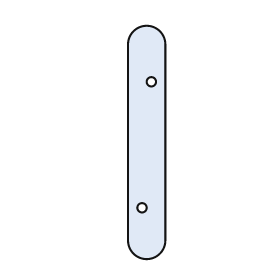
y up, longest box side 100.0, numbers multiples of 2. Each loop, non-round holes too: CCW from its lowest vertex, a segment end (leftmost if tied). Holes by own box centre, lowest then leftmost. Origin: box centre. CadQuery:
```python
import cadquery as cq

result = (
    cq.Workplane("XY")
    .moveTo(-8.0, -42.0)
    .threePointArc((0.0, -50.0), (8.0, -42.0))
    .lineTo(8.0, 42.0)
    .threePointArc((0.0, 50.0), (-8.0, 42.0))
    .close()
    .moveTo(-2.0, -28.0)
    .circle(2.0)
    .moveTo(2.0, 26.0)
    .circle(2.0)
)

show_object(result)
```